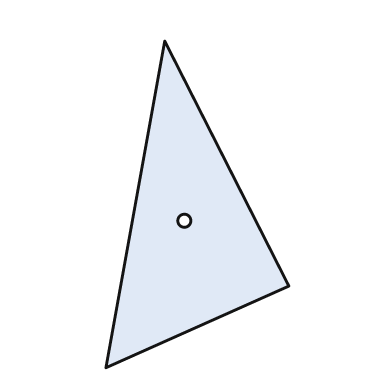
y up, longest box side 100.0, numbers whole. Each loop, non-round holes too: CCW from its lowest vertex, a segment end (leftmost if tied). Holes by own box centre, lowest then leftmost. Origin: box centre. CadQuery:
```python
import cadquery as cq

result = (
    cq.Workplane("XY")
    .moveTo(-28.0, -50.0)
    .lineTo(28.0, -25.0)
    .lineTo(-10.0, 50.0)
    .close()
    .moveTo(-4.0, -5.0)
    .circle(2.0)
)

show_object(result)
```